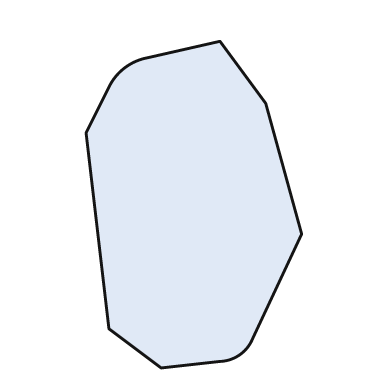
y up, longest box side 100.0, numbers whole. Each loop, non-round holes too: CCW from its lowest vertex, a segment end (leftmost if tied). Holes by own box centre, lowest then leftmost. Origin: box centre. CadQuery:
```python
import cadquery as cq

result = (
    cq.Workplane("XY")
    .moveTo(-10.0, -50.0)
    .lineTo(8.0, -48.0)
    .threePointArc((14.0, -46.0), (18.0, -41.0))
    .lineTo(33.0, -9.0)
    .lineTo(22.0, 31.0)
    .lineTo(8.0, 50.0)
    .lineTo(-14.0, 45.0)
    .threePointArc((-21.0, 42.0), (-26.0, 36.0))
    .lineTo(-33.0, 22.0)
    .lineTo(-26.0, -38.0)
    .close()
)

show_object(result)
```